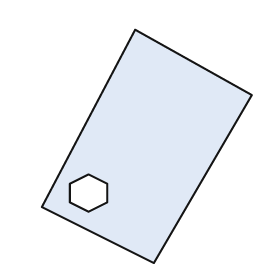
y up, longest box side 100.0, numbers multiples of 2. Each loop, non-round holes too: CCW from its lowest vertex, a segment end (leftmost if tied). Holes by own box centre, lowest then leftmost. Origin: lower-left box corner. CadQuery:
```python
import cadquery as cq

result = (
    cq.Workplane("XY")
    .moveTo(48.0, 0.0)
    .lineTo(90.0, 72.0)
    .lineTo(40.0, 100.0)
    .lineTo(0.0, 24.0)
    .close()
    .moveTo(20.0, 22.0)
    .lineTo(28.0, 26.0)
    .lineTo(28.0, 34.0)
    .lineTo(20.0, 38.0)
    .lineTo(12.0, 34.0)
    .lineTo(12.0, 26.0)
    .close()
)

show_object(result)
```